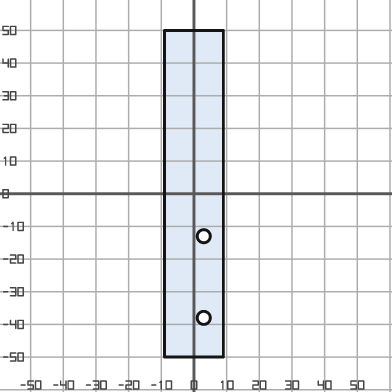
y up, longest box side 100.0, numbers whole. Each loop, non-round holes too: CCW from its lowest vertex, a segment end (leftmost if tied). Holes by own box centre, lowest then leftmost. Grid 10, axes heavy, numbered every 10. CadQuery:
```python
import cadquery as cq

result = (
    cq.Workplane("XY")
    .moveTo(-9.0, -50.0)
    .lineTo(9.0, -50.0)
    .lineTo(9.0, 50.0)
    .lineTo(-9.0, 50.0)
    .close()
    .moveTo(3.0, -38.0)
    .circle(2.0)
    .moveTo(3.0, -13.0)
    .circle(2.0)
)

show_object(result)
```